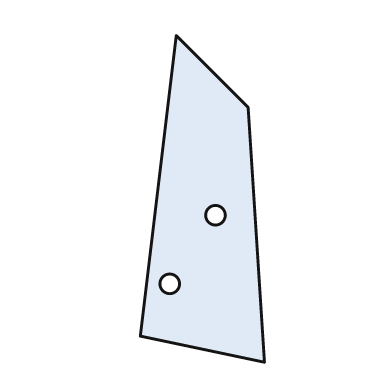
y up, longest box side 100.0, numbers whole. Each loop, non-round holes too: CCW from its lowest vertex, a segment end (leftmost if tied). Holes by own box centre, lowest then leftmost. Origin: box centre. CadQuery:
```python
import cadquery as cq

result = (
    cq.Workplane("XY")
    .moveTo(19.0, -50.0)
    .lineTo(14.0, 28.0)
    .lineTo(-8.0, 50.0)
    .lineTo(-19.0, -42.0)
    .close()
    .moveTo(-10.0, -26.0)
    .circle(3.0)
    .moveTo(4.0, -5.0)
    .circle(3.0)
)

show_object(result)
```